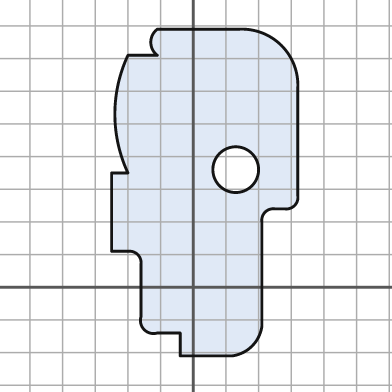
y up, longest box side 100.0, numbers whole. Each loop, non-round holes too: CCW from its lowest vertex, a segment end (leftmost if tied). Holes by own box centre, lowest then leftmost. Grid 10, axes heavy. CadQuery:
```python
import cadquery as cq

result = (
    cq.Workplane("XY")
    .moveTo(-4.0, -21.0)
    .lineTo(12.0, -21.0)
    .threePointArc((18.0, -18.0), (21.0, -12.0))
    .lineTo(21.0, 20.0)
    .threePointArc((22.0, 23.0), (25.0, 24.0))
    .lineTo(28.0, 24.0)
    .threePointArc((31.0, 25.0), (32.0, 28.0))
    .lineTo(32.0, 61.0)
    .threePointArc((27.0, 74.0), (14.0, 79.0))
    .lineTo(-11.0, 79.0)
    .threePointArc((-13.0, 75.0), (-11.0, 71.0))
    .lineTo(-20.0, 71.0)
    .threePointArc((-24.0, 53.0), (-20.0, 35.0))
    .lineTo(-25.0, 35.0)
    .lineTo(-25.0, 11.0)
    .lineTo(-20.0, 11.0)
    .threePointArc((-17.0, 10.0), (-16.0, 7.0))
    .lineTo(-16.0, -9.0)
    .threePointArc((-15.0, -13.0), (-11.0, -14.0))
    .lineTo(-4.0, -14.0)
    .close()
    .moveTo(13.0, 36.0)
    .circle(7.0)
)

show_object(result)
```